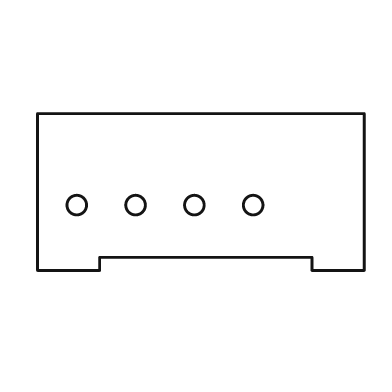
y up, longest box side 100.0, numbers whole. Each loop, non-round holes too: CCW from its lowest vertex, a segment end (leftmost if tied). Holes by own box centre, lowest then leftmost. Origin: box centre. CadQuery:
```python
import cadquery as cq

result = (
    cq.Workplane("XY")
    .moveTo(-50.0, -24.0)
    .lineTo(-31.0, -24.0)
    .lineTo(-31.0, -20.0)
    .lineTo(34.0, -20.0)
    .lineTo(34.0, -24.0)
    .lineTo(50.0, -24.0)
    .lineTo(50.0, 24.0)
    .lineTo(-50.0, 24.0)
    .close()
    .moveTo(-38.0, -4.0)
    .circle(3.0)
    .moveTo(-20.0, -4.0)
    .circle(3.0)
    .moveTo(-2.0, -4.0)
    .circle(3.0)
    .moveTo(16.0, -4.0)
    .circle(3.0)
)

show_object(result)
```